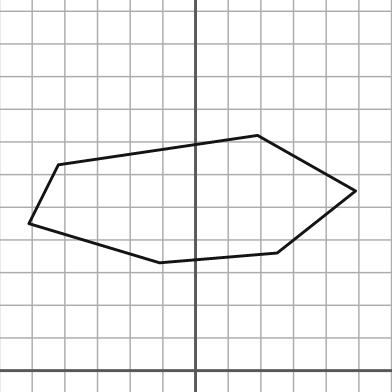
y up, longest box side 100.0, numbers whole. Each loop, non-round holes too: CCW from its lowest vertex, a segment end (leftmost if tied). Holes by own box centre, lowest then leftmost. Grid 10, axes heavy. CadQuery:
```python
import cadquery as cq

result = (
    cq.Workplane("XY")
    .moveTo(-11.0, 33.0)
    .lineTo(25.0, 36.0)
    .lineTo(49.0, 55.0)
    .lineTo(19.0, 72.0)
    .lineTo(-42.0, 63.0)
    .lineTo(-51.0, 45.0)
    .close()
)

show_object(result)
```